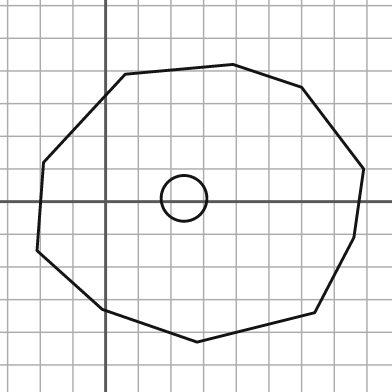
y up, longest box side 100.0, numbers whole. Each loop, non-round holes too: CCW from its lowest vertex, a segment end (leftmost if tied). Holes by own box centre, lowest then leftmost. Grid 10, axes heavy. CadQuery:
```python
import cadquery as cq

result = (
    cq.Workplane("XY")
    .moveTo(28.0, -43.0)
    .lineTo(64.0, -34.0)
    .lineTo(76.0, -11.0)
    .lineTo(79.0, 10.0)
    .lineTo(60.0, 35.0)
    .lineTo(39.0, 42.0)
    .lineTo(6.0, 39.0)
    .lineTo(-19.0, 12.0)
    .lineTo(-21.0, -15.0)
    .lineTo(-1.0, -33.0)
    .close()
    .moveTo(24.0, 1.0)
    .circle(7.0)
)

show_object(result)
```